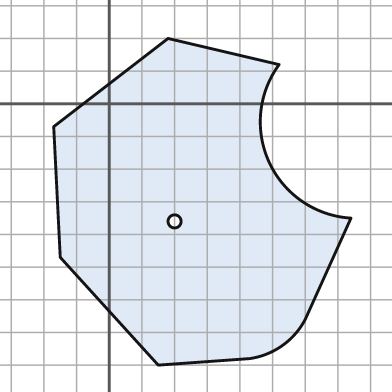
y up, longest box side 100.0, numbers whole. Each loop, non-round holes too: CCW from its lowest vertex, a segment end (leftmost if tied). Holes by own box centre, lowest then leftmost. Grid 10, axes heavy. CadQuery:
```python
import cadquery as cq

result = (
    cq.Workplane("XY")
    .moveTo(15.0, -80.0)
    .lineTo(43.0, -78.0)
    .threePointArc((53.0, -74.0), (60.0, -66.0))
    .lineTo(74.0, -35.0)
    .threePointArc((49.0, -18.0), (52.0, 12.0))
    .lineTo(18.0, 20.0)
    .lineTo(-17.0, -7.0)
    .lineTo(-15.0, -47.0)
    .close()
    .moveTo(20.0, -36.0)
    .circle(2.0)
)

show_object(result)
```